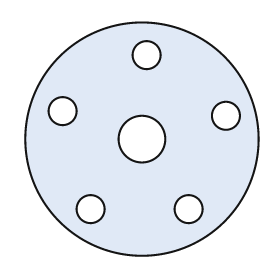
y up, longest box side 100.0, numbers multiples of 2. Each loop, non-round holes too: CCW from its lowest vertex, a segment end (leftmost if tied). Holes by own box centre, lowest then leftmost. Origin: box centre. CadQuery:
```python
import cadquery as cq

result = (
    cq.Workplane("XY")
    .moveTo(0.0, 0.0)
    .circle(50.0)
    .moveTo(-22.0, -30.0)
    .circle(6.0)
    .moveTo(20.0, -30.0)
    .circle(6.0)
    .moveTo(0.0, 0.0)
    .circle(10.0)
    .moveTo(36.0, 10.0)
    .circle(6.0)
    .moveTo(-34.0, 12.0)
    .circle(6.0)
    .moveTo(2.0, 36.0)
    .circle(6.0)
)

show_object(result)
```